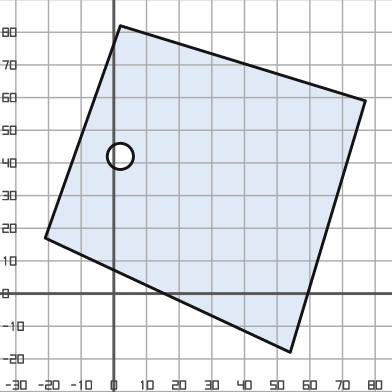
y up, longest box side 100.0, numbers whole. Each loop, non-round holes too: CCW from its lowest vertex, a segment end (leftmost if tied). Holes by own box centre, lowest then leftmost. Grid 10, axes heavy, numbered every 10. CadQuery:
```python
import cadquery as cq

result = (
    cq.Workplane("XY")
    .moveTo(54.0, -18.0)
    .lineTo(77.0, 59.0)
    .lineTo(2.0, 82.0)
    .lineTo(-21.0, 17.0)
    .close()
    .moveTo(2.0, 42.0)
    .circle(4.0)
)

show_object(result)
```